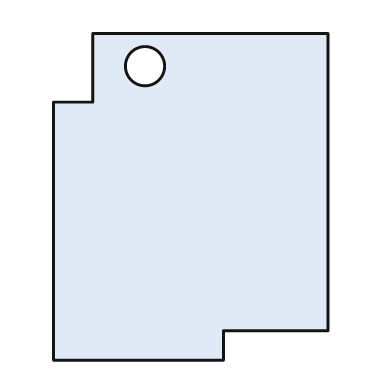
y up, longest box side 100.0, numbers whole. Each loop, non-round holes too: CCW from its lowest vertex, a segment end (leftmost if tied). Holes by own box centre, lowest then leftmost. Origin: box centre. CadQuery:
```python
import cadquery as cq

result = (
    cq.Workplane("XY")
    .moveTo(-42.0, -50.0)
    .lineTo(10.0, -50.0)
    .lineTo(10.0, -41.0)
    .lineTo(42.0, -41.0)
    .lineTo(42.0, 50.0)
    .lineTo(-30.0, 50.0)
    .lineTo(-30.0, 29.0)
    .lineTo(-42.0, 29.0)
    .close()
    .moveTo(-14.0, 40.0)
    .circle(6.0)
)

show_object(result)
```